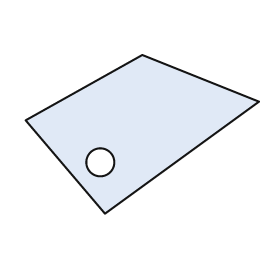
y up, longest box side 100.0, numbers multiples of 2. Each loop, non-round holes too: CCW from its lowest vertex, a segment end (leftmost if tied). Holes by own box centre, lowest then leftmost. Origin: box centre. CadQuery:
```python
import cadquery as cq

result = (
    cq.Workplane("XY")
    .moveTo(-16.0, -34.0)
    .lineTo(50.0, 14.0)
    .lineTo(0.0, 34.0)
    .lineTo(-50.0, 6.0)
    .close()
    .moveTo(-18.0, -12.0)
    .circle(6.0)
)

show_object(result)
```